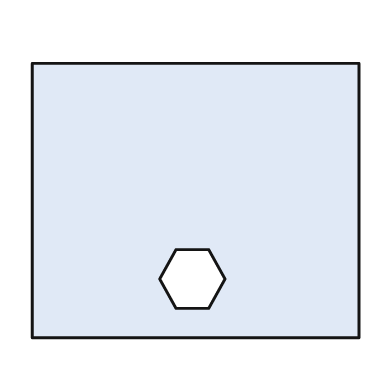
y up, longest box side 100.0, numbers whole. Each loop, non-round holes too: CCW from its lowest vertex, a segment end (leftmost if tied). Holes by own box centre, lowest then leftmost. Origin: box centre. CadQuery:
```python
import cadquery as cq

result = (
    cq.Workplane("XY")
    .moveTo(-50.0, -42.0)
    .lineTo(50.0, -42.0)
    .lineTo(50.0, 42.0)
    .lineTo(-50.0, 42.0)
    .close()
    .moveTo(-6.0, -33.0)
    .lineTo(4.0, -33.0)
    .lineTo(9.0, -24.0)
    .lineTo(4.0, -15.0)
    .lineTo(-6.0, -15.0)
    .lineTo(-11.0, -24.0)
    .close()
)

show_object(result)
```